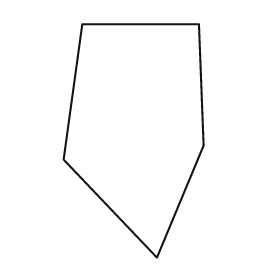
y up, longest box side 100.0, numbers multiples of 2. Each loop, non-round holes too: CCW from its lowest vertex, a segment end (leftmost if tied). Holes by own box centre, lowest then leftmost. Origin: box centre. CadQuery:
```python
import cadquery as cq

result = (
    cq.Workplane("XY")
    .moveTo(10.0, -50.0)
    .lineTo(30.0, -2.0)
    .lineTo(28.0, 50.0)
    .lineTo(-22.0, 50.0)
    .lineTo(-30.0, -8.0)
    .close()
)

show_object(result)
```